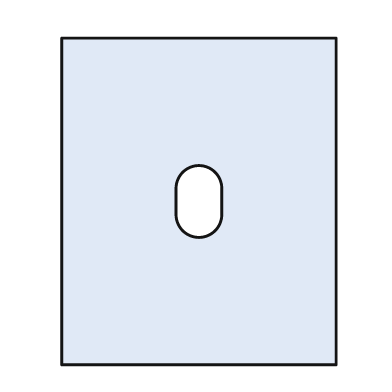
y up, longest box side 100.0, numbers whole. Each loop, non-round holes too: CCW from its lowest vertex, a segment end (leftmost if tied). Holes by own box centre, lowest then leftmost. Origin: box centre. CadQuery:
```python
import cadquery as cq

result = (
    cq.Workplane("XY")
    .moveTo(-42.0, -50.0)
    .lineTo(42.0, -50.0)
    .lineTo(42.0, 50.0)
    .lineTo(-42.0, 50.0)
    .close()
    .moveTo(-7.0, -4.0)
    .threePointArc((0.0, -11.0), (7.0, -4.0))
    .lineTo(7.0, 4.0)
    .threePointArc((0.0, 11.0), (-7.0, 4.0))
    .close()
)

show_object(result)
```